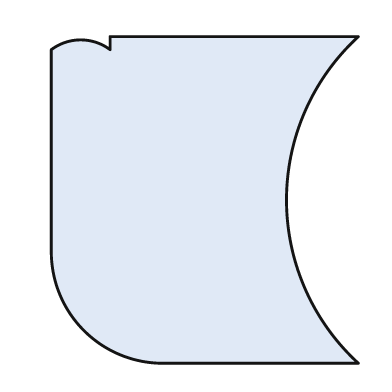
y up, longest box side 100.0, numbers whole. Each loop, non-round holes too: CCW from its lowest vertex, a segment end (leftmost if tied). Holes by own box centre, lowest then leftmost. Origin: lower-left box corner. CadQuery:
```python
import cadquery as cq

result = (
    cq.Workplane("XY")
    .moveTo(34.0, 0.0)
    .lineTo(94.0, 0.0)
    .threePointArc((72.0, 50.0), (94.0, 100.0))
    .lineTo(18.0, 100.0)
    .lineTo(18.0, 96.0)
    .threePointArc((9.0, 99.0), (0.0, 96.0))
    .lineTo(0.0, 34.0)
    .threePointArc((10.0, 10.0), (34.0, 0.0))
    .close()
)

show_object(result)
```